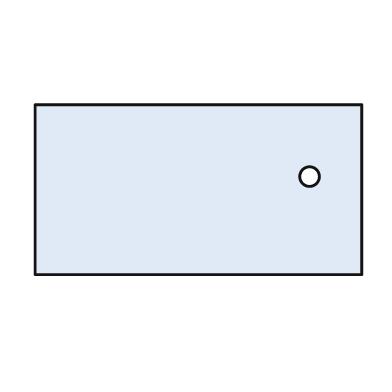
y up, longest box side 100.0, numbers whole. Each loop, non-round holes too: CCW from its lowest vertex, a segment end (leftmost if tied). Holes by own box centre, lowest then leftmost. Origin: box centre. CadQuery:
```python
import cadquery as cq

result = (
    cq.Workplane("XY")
    .moveTo(-50.0, -26.0)
    .lineTo(50.0, -26.0)
    .lineTo(50.0, 26.0)
    .lineTo(-50.0, 26.0)
    .close()
    .moveTo(34.0, 4.0)
    .circle(3.0)
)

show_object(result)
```